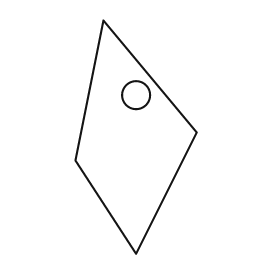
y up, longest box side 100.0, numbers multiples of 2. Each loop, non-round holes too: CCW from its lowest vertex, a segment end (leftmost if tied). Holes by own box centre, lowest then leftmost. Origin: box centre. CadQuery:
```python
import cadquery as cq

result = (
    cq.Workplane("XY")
    .moveTo(0.0, -50.0)
    .lineTo(26.0, 2.0)
    .lineTo(-14.0, 50.0)
    .lineTo(-26.0, -10.0)
    .close()
    .moveTo(0.0, 18.0)
    .circle(6.0)
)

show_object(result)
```